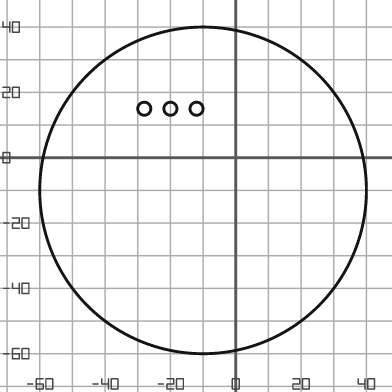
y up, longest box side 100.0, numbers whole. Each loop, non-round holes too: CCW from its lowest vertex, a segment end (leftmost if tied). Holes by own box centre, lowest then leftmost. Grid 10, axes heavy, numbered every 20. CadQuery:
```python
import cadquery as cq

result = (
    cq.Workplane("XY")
    .moveTo(-10.0, -10.0)
    .circle(50.0)
    .moveTo(-28.0, 15.0)
    .circle(2.0)
    .moveTo(-20.0, 15.0)
    .circle(2.0)
    .moveTo(-12.0, 15.0)
    .circle(2.0)
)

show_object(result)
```